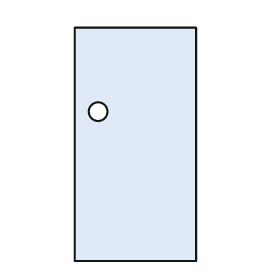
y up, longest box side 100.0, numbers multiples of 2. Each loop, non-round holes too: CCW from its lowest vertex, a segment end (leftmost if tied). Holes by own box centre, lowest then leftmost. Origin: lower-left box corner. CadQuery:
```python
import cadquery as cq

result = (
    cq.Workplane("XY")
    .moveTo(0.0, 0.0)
    .lineTo(52.0, 0.0)
    .lineTo(52.0, 100.0)
    .lineTo(0.0, 100.0)
    .close()
    .moveTo(10.0, 64.0)
    .circle(4.0)
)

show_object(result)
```